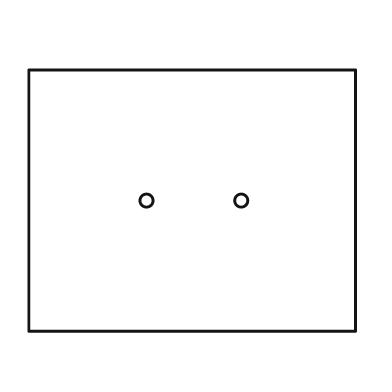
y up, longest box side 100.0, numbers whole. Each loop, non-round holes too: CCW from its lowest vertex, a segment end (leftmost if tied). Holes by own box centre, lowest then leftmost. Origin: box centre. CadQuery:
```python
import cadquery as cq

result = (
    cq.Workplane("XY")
    .moveTo(-50.0, -40.0)
    .lineTo(50.0, -40.0)
    .lineTo(50.0, 40.0)
    .lineTo(-50.0, 40.0)
    .close()
    .moveTo(-14.0, 0.0)
    .circle(2.0)
    .moveTo(15.0, 0.0)
    .circle(2.0)
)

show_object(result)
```